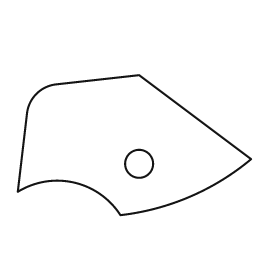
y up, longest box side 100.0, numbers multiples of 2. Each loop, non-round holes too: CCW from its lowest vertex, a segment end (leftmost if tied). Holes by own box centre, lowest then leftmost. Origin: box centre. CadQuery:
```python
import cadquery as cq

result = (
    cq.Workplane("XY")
    .moveTo(-6.0, -30.0)
    .threePointArc((24.0, -22.0), (50.0, -6.0))
    .lineTo(2.0, 30.0)
    .lineTo(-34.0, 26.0)
    .threePointArc((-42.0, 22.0), (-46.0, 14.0))
    .lineTo(-50.0, -20.0)
    .threePointArc((-26.0, -16.0), (-6.0, -30.0))
    .close()
    .moveTo(2.0, -8.0)
    .circle(6.0)
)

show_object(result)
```